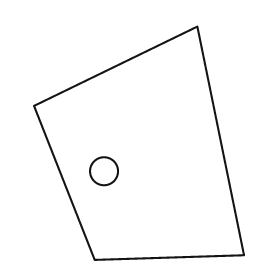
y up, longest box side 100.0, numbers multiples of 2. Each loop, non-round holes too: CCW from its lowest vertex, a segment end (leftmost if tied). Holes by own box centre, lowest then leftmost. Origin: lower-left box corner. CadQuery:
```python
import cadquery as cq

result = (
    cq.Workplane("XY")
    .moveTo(26.0, 0.0)
    .lineTo(90.0, 2.0)
    .lineTo(70.0, 100.0)
    .lineTo(0.0, 66.0)
    .close()
    .moveTo(30.0, 38.0)
    .circle(6.0)
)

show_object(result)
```